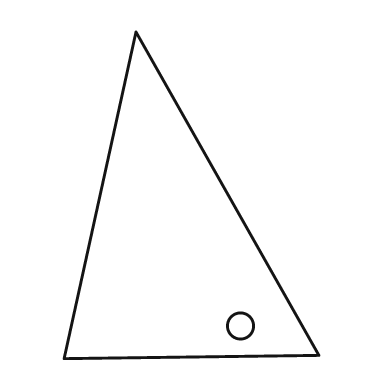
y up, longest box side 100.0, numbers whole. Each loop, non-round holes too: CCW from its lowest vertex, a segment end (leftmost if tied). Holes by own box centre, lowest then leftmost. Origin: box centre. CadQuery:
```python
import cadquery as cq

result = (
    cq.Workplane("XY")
    .moveTo(-39.0, -50.0)
    .lineTo(39.0, -49.0)
    .lineTo(-17.0, 50.0)
    .close()
    .moveTo(15.0, -40.0)
    .circle(4.0)
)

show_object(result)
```